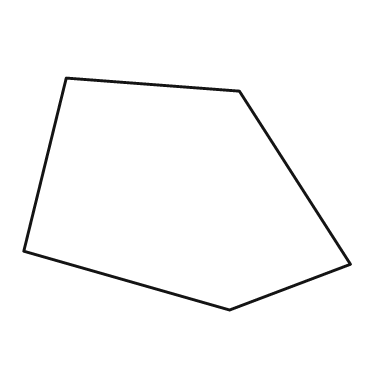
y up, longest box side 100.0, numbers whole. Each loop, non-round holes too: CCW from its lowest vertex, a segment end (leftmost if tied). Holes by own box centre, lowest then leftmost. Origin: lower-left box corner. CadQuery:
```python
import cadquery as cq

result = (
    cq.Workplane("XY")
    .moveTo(63.0, 0.0)
    .lineTo(100.0, 14.0)
    .lineTo(66.0, 67.0)
    .lineTo(13.0, 71.0)
    .lineTo(0.0, 18.0)
    .close()
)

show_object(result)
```